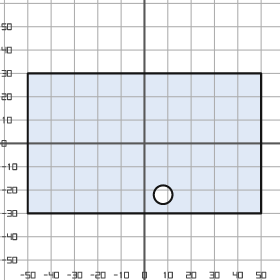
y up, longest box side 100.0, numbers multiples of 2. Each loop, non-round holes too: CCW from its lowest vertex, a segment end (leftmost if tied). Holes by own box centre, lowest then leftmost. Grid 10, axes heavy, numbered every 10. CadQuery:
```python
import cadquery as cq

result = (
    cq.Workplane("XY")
    .moveTo(-50.0, -30.0)
    .lineTo(50.0, -30.0)
    .lineTo(50.0, 30.0)
    .lineTo(-50.0, 30.0)
    .close()
    .moveTo(8.0, -22.0)
    .circle(4.0)
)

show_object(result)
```